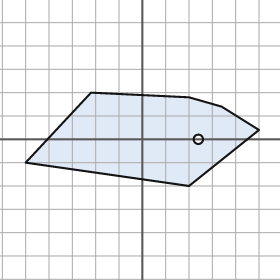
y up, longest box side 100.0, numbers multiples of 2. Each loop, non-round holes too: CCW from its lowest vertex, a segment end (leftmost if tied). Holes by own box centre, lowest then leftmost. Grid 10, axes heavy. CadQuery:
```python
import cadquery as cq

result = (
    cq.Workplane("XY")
    .moveTo(20.0, -20.0)
    .lineTo(50.0, 4.0)
    .lineTo(34.0, 14.0)
    .lineTo(20.0, 18.0)
    .lineTo(-22.0, 20.0)
    .lineTo(-50.0, -10.0)
    .close()
    .moveTo(24.0, 0.0)
    .circle(2.0)
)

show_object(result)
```